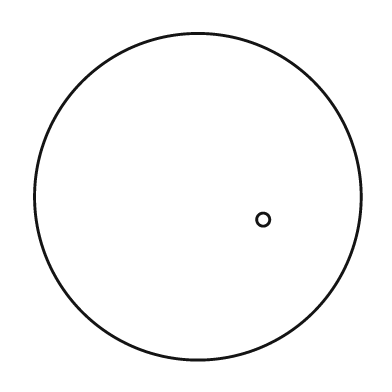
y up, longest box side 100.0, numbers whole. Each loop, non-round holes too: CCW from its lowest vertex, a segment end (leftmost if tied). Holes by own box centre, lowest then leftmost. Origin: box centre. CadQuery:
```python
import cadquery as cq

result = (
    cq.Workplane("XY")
    .moveTo(0.0, 0.0)
    .circle(50.0)
    .moveTo(20.0, -7.0)
    .circle(2.0)
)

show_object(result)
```